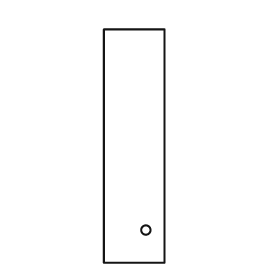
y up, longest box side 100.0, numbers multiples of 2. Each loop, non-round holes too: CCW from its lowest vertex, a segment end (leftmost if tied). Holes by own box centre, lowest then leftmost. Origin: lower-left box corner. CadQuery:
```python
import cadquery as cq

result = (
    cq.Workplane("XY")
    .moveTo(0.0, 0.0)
    .lineTo(26.0, 0.0)
    .lineTo(26.0, 100.0)
    .lineTo(0.0, 100.0)
    .close()
    .moveTo(18.0, 14.0)
    .circle(2.0)
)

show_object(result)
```